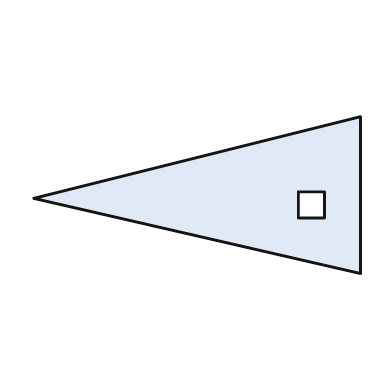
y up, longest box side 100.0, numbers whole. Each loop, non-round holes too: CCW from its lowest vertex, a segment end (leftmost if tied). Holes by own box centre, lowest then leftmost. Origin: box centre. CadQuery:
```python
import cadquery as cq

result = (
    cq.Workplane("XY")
    .moveTo(50.0, -24.0)
    .lineTo(50.0, 24.0)
    .lineTo(-50.0, -1.0)
    .close()
    .moveTo(31.0, -7.0)
    .lineTo(39.0, -7.0)
    .lineTo(39.0, 1.0)
    .lineTo(31.0, 1.0)
    .close()
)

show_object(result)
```